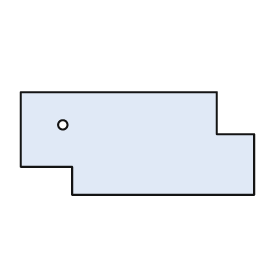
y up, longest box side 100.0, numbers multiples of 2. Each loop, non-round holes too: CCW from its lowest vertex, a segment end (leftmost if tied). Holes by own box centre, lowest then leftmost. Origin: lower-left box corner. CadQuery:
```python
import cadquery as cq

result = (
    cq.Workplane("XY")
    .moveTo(22.0, 0.0)
    .lineTo(100.0, 0.0)
    .lineTo(100.0, 26.0)
    .lineTo(84.0, 26.0)
    .lineTo(84.0, 44.0)
    .lineTo(0.0, 44.0)
    .lineTo(0.0, 12.0)
    .lineTo(22.0, 12.0)
    .close()
    .moveTo(18.0, 30.0)
    .circle(2.0)
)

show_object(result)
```